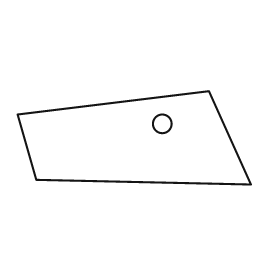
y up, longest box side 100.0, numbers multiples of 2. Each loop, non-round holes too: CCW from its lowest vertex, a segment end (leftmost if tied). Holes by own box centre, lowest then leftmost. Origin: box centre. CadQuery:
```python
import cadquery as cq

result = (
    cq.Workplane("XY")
    .moveTo(50.0, -20.0)
    .lineTo(32.0, 20.0)
    .lineTo(-50.0, 10.0)
    .lineTo(-42.0, -18.0)
    .close()
    .moveTo(12.0, 6.0)
    .circle(4.0)
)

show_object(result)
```